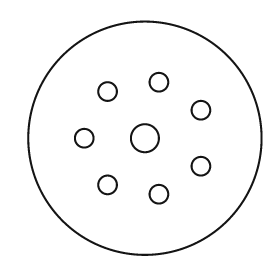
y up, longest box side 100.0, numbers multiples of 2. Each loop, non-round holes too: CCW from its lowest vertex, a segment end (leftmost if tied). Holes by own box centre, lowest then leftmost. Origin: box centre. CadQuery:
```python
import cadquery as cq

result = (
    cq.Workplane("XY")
    .moveTo(0.0, 0.0)
    .circle(50.0)
    .moveTo(6.0, -24.0)
    .circle(4.0)
    .moveTo(-16.0, -20.0)
    .circle(4.0)
    .moveTo(24.0, -12.0)
    .circle(4.0)
    .moveTo(-26.0, 0.0)
    .circle(4.0)
    .moveTo(0.0, 0.0)
    .circle(6.0)
    .moveTo(24.0, 12.0)
    .circle(4.0)
    .moveTo(-16.0, 20.0)
    .circle(4.0)
    .moveTo(6.0, 24.0)
    .circle(4.0)
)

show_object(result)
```